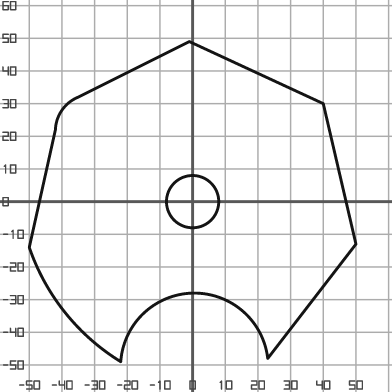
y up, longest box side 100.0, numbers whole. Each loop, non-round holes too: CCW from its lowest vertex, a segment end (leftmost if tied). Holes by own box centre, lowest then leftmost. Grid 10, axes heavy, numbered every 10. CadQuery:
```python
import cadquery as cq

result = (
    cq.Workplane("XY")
    .moveTo(-22.0, -49.0)
    .threePointArc((0.0, -28.0), (23.0, -48.0))
    .lineTo(50.0, -13.0)
    .lineTo(40.0, 30.0)
    .lineTo(-1.0, 49.0)
    .lineTo(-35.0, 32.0)
    .threePointArc((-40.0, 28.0), (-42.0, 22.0))
    .lineTo(-50.0, -14.0)
    .threePointArc((-39.0, -34.0), (-22.0, -49.0))
    .close()
    .moveTo(0.0, 0.0)
    .circle(8.0)
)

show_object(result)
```